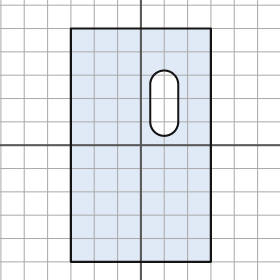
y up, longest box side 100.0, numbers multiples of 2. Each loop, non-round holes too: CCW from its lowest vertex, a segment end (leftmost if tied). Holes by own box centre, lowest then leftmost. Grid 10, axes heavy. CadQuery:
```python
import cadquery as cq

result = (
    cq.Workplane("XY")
    .moveTo(-30.0, -50.0)
    .lineTo(30.0, -50.0)
    .lineTo(30.0, 50.0)
    .lineTo(-30.0, 50.0)
    .close()
    .moveTo(4.0, 10.0)
    .threePointArc((10.0, 4.0), (16.0, 10.0))
    .lineTo(16.0, 26.0)
    .threePointArc((10.0, 32.0), (4.0, 26.0))
    .close()
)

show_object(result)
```